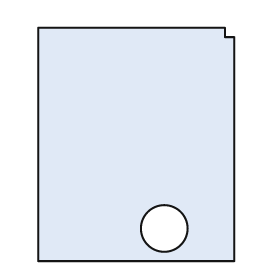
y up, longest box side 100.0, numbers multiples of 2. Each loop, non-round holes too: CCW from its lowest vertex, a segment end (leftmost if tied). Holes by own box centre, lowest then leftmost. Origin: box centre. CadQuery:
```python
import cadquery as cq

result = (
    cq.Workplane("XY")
    .moveTo(-42.0, -50.0)
    .lineTo(42.0, -50.0)
    .lineTo(42.0, 46.0)
    .lineTo(38.0, 46.0)
    .lineTo(38.0, 50.0)
    .lineTo(-42.0, 50.0)
    .close()
    .moveTo(12.0, -36.0)
    .circle(10.0)
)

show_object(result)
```